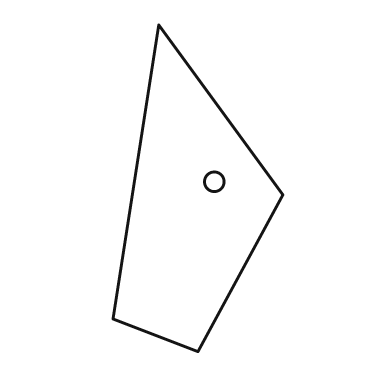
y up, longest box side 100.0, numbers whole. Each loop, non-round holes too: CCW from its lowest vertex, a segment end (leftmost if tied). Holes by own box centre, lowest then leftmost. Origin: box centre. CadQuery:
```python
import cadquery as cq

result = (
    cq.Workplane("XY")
    .moveTo(0.0, -50.0)
    .lineTo(26.0, -2.0)
    .lineTo(-12.0, 50.0)
    .lineTo(-26.0, -40.0)
    .close()
    .moveTo(5.0, 2.0)
    .circle(3.0)
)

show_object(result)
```